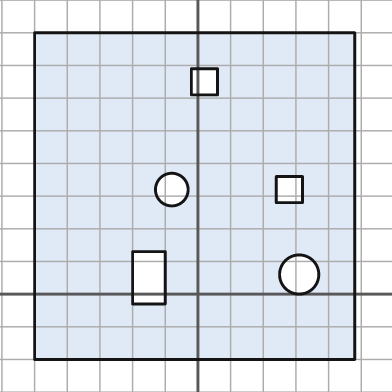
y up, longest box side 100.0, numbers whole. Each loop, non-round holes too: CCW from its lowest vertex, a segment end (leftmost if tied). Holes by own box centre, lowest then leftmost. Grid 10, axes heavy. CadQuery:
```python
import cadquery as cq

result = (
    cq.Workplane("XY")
    .moveTo(-50.0, -20.0)
    .lineTo(48.0, -20.0)
    .lineTo(48.0, 80.0)
    .lineTo(-50.0, 80.0)
    .close()
    .moveTo(-20.0, -3.0)
    .lineTo(-10.0, -3.0)
    .lineTo(-10.0, 13.0)
    .lineTo(-20.0, 13.0)
    .close()
    .moveTo(31.0, 6.0)
    .circle(6.0)
    .moveTo(-8.0, 32.0)
    .circle(5.0)
    .moveTo(24.0, 28.0)
    .lineTo(32.0, 28.0)
    .lineTo(32.0, 36.0)
    .lineTo(24.0, 36.0)
    .close()
    .moveTo(-2.0, 61.0)
    .lineTo(6.0, 61.0)
    .lineTo(6.0, 69.0)
    .lineTo(-2.0, 69.0)
    .close()
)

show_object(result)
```